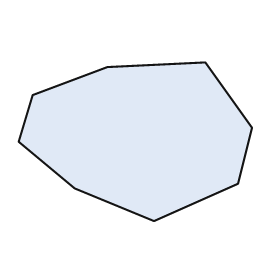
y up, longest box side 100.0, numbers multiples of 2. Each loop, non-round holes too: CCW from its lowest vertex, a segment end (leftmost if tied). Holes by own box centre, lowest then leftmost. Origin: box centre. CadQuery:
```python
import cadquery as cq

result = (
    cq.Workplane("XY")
    .moveTo(8.0, -34.0)
    .lineTo(44.0, -18.0)
    .lineTo(50.0, 6.0)
    .lineTo(30.0, 34.0)
    .lineTo(-12.0, 32.0)
    .lineTo(-44.0, 20.0)
    .lineTo(-50.0, 0.0)
    .lineTo(-26.0, -20.0)
    .close()
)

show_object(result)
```